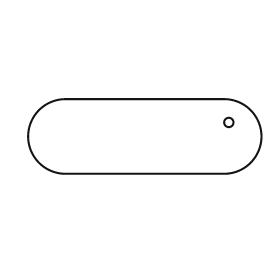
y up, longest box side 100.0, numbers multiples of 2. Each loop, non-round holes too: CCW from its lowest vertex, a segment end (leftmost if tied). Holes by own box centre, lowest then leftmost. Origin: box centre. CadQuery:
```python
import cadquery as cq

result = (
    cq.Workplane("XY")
    .moveTo(-34.0, -16.0)
    .lineTo(34.0, -16.0)
    .threePointArc((50.0, 0.0), (34.0, 16.0))
    .lineTo(-34.0, 16.0)
    .threePointArc((-50.0, 0.0), (-34.0, -16.0))
    .close()
    .moveTo(36.0, 6.0)
    .circle(2.0)
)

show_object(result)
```